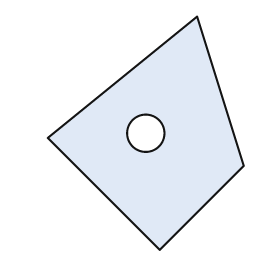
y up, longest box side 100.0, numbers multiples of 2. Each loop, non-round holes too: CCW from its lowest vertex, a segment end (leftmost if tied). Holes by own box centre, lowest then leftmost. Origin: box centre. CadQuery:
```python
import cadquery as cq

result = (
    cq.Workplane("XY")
    .moveTo(6.0, -50.0)
    .lineTo(42.0, -14.0)
    .lineTo(22.0, 50.0)
    .lineTo(-42.0, -2.0)
    .close()
    .moveTo(0.0, 0.0)
    .circle(8.0)
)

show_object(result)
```